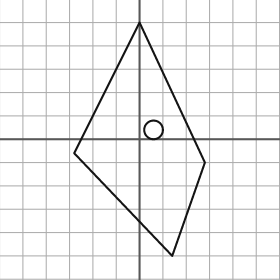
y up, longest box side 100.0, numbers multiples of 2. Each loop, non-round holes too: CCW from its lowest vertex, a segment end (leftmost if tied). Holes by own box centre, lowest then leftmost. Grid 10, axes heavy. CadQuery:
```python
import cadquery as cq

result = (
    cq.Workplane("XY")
    .moveTo(14.0, -50.0)
    .lineTo(28.0, -10.0)
    .lineTo(0.0, 50.0)
    .lineTo(-28.0, -6.0)
    .close()
    .moveTo(6.0, 4.0)
    .circle(4.0)
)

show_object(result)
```